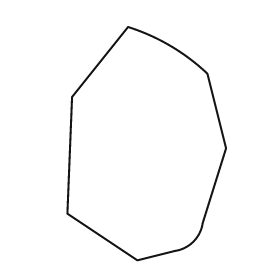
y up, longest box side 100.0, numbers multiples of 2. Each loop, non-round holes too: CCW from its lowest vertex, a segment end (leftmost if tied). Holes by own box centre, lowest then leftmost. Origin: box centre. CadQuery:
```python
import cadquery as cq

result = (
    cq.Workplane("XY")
    .moveTo(-4.0, -50.0)
    .lineTo(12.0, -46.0)
    .threePointArc((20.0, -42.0), (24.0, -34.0))
    .lineTo(34.0, -2.0)
    .lineTo(26.0, 30.0)
    .threePointArc((10.0, 42.0), (-8.0, 50.0))
    .lineTo(-32.0, 20.0)
    .lineTo(-34.0, -30.0)
    .close()
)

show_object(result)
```